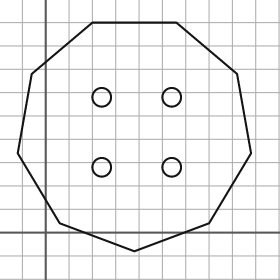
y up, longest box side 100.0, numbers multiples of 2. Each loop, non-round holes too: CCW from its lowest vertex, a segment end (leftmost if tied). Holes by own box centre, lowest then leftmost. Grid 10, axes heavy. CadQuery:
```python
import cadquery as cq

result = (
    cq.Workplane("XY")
    .moveTo(38.0, -8.0)
    .lineTo(70.0, 4.0)
    .lineTo(88.0, 34.0)
    .lineTo(82.0, 68.0)
    .lineTo(56.0, 90.0)
    .lineTo(20.0, 90.0)
    .lineTo(-6.0, 68.0)
    .lineTo(-12.0, 34.0)
    .lineTo(6.0, 4.0)
    .close()
    .moveTo(24.0, 28.0)
    .circle(4.0)
    .moveTo(54.0, 28.0)
    .circle(4.0)
    .moveTo(24.0, 58.0)
    .circle(4.0)
    .moveTo(54.0, 58.0)
    .circle(4.0)
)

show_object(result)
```